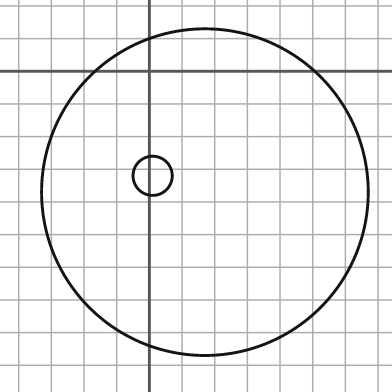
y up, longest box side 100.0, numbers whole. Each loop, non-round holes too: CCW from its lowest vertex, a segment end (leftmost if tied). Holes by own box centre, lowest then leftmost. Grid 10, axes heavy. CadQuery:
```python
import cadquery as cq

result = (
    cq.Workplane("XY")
    .moveTo(17.0, -37.0)
    .circle(50.0)
    .moveTo(1.0, -32.0)
    .circle(6.0)
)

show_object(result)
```